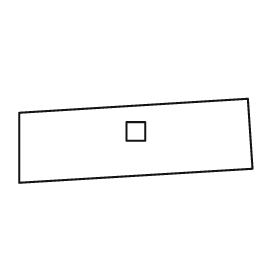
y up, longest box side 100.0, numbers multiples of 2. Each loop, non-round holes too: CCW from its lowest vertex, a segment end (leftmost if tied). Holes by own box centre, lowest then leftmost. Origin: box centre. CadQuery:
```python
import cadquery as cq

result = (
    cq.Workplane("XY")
    .moveTo(-50.0, -18.0)
    .lineTo(50.0, -12.0)
    .lineTo(48.0, 18.0)
    .lineTo(-50.0, 12.0)
    .close()
    .moveTo(-4.0, 0.0)
    .lineTo(4.0, 0.0)
    .lineTo(4.0, 8.0)
    .lineTo(-4.0, 8.0)
    .close()
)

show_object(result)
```